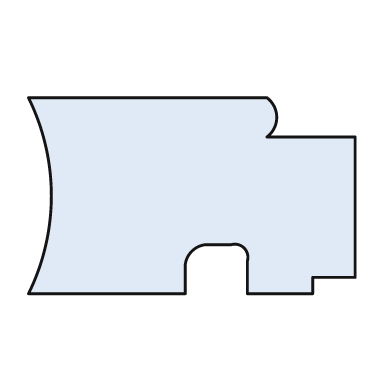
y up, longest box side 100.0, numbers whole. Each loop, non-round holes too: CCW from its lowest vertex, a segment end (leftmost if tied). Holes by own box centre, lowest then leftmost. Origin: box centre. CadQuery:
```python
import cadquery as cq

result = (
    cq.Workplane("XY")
    .moveTo(-50.0, -30.0)
    .lineTo(-2.0, -30.0)
    .lineTo(-2.0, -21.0)
    .threePointArc((0.0, -17.0), (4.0, -15.0))
    .lineTo(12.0, -15.0)
    .threePointArc((16.0, -16.0), (17.0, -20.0))
    .lineTo(17.0, -30.0)
    .lineTo(37.0, -30.0)
    .lineTo(37.0, -25.0)
    .lineTo(50.0, -25.0)
    .lineTo(50.0, 18.0)
    .lineTo(23.0, 18.0)
    .threePointArc((26.0, 24.0), (23.0, 30.0))
    .lineTo(-50.0, 30.0)
    .threePointArc((-43.0, 0.0), (-50.0, -30.0))
    .close()
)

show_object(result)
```